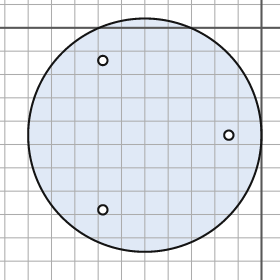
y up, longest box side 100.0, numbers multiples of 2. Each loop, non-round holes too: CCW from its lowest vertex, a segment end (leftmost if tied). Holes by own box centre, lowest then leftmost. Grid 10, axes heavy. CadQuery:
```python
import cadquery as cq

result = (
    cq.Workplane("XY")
    .moveTo(-50.0, -46.0)
    .circle(50.0)
    .moveTo(-68.0, -78.0)
    .circle(2.0)
    .moveTo(-14.0, -46.0)
    .circle(2.0)
    .moveTo(-68.0, -14.0)
    .circle(2.0)
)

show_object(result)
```